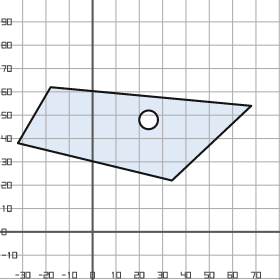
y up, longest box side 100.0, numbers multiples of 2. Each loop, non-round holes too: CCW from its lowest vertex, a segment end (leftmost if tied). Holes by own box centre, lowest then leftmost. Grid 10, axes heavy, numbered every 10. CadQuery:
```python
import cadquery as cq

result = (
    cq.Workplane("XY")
    .moveTo(34.0, 22.0)
    .lineTo(68.0, 54.0)
    .lineTo(-18.0, 62.0)
    .lineTo(-32.0, 38.0)
    .close()
    .moveTo(24.0, 48.0)
    .circle(4.0)
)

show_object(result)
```